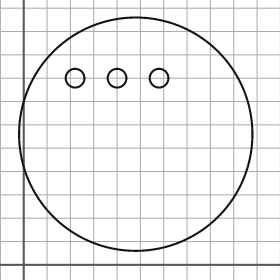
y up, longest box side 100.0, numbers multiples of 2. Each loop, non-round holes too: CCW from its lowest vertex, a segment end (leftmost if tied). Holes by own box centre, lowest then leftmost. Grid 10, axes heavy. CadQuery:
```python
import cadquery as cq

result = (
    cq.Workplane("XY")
    .moveTo(48.0, 56.0)
    .circle(50.0)
    .moveTo(22.0, 80.0)
    .circle(4.0)
    .moveTo(40.0, 80.0)
    .circle(4.0)
    .moveTo(58.0, 80.0)
    .circle(4.0)
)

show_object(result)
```